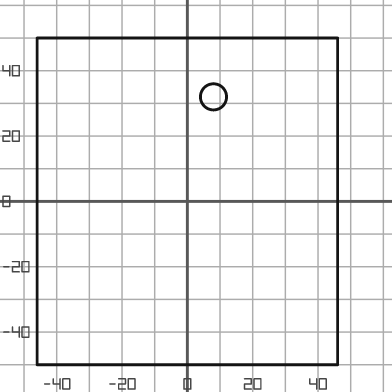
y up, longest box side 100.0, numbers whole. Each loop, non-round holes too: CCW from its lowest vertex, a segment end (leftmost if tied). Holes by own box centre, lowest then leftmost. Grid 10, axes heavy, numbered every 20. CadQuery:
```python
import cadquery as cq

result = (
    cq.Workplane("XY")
    .moveTo(-46.0, -50.0)
    .lineTo(46.0, -50.0)
    .lineTo(46.0, 50.0)
    .lineTo(-46.0, 50.0)
    .close()
    .moveTo(8.0, 32.0)
    .circle(4.0)
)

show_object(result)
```